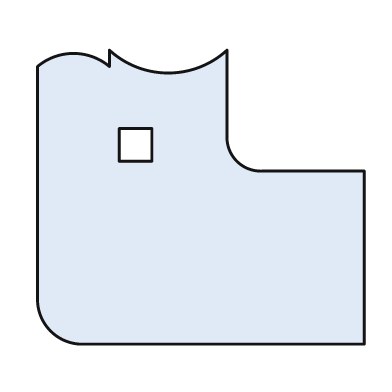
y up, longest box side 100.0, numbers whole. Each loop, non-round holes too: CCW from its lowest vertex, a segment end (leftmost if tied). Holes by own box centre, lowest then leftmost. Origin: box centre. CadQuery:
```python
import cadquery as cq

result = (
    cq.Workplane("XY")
    .moveTo(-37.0, -45.0)
    .lineTo(50.0, -45.0)
    .lineTo(50.0, 8.0)
    .lineTo(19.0, 8.0)
    .threePointArc((11.0, 11.0), (8.0, 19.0))
    .lineTo(8.0, 45.0)
    .threePointArc((-10.0, 38.0), (-28.0, 45.0))
    .lineTo(-28.0, 40.0)
    .threePointArc((-39.0, 44.0), (-50.0, 40.0))
    .lineTo(-50.0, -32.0)
    .threePointArc((-46.0, -41.0), (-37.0, -45.0))
    .close()
    .moveTo(-25.0, 11.0)
    .lineTo(-15.0, 11.0)
    .lineTo(-15.0, 21.0)
    .lineTo(-25.0, 21.0)
    .close()
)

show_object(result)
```